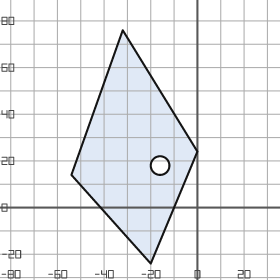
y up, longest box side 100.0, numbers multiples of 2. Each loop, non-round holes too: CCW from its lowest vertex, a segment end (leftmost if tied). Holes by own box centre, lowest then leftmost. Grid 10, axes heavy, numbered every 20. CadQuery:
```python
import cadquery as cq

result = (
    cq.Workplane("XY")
    .moveTo(-20.0, -24.0)
    .lineTo(0.0, 24.0)
    .lineTo(-32.0, 76.0)
    .lineTo(-54.0, 14.0)
    .close()
    .moveTo(-16.0, 18.0)
    .circle(4.0)
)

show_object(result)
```